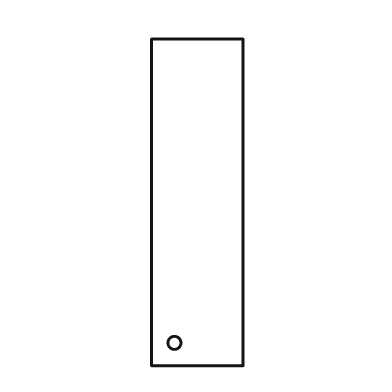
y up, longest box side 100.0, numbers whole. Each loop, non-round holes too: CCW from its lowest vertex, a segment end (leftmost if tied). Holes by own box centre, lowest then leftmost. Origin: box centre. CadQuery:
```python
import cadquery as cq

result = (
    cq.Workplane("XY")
    .moveTo(-14.0, -50.0)
    .lineTo(14.0, -50.0)
    .lineTo(14.0, 50.0)
    .lineTo(-14.0, 50.0)
    .close()
    .moveTo(-7.0, -43.0)
    .circle(2.0)
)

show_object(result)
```